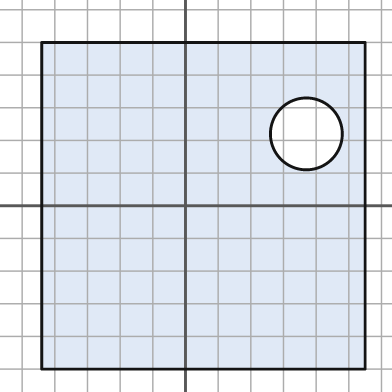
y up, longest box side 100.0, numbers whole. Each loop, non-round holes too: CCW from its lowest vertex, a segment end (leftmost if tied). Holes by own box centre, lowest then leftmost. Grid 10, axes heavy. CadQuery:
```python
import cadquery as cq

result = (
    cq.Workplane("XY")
    .moveTo(-44.0, -50.0)
    .lineTo(55.0, -50.0)
    .lineTo(55.0, 50.0)
    .lineTo(-44.0, 50.0)
    .close()
    .moveTo(37.0, 22.0)
    .circle(11.0)
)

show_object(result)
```